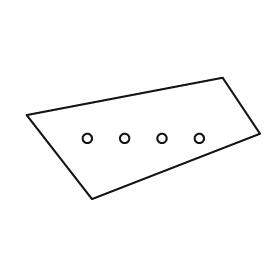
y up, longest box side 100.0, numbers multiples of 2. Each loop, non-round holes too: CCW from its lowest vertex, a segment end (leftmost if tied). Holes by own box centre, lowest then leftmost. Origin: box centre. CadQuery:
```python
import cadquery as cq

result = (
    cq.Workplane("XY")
    .moveTo(-22.0, -26.0)
    .lineTo(50.0, 2.0)
    .lineTo(34.0, 26.0)
    .lineTo(-50.0, 10.0)
    .close()
    .moveTo(-24.0, 0.0)
    .circle(2.0)
    .moveTo(-8.0, 0.0)
    .circle(2.0)
    .moveTo(8.0, 0.0)
    .circle(2.0)
    .moveTo(24.0, 0.0)
    .circle(2.0)
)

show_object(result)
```